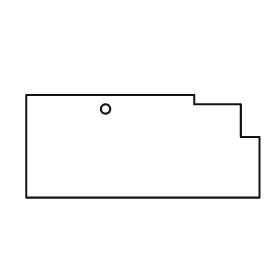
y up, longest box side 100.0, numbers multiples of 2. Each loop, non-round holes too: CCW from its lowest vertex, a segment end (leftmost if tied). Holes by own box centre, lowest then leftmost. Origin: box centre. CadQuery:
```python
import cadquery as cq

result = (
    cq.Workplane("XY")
    .moveTo(-50.0, -22.0)
    .lineTo(50.0, -22.0)
    .lineTo(50.0, 4.0)
    .lineTo(42.0, 4.0)
    .lineTo(42.0, 18.0)
    .lineTo(22.0, 18.0)
    .lineTo(22.0, 22.0)
    .lineTo(-50.0, 22.0)
    .close()
    .moveTo(-16.0, 16.0)
    .circle(2.0)
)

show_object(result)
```